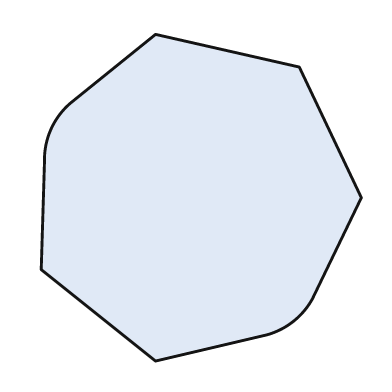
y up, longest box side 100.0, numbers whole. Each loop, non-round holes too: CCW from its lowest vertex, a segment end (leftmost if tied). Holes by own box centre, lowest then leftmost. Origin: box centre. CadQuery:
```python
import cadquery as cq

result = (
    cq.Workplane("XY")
    .moveTo(-14.0, -50.0)
    .lineTo(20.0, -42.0)
    .threePointArc((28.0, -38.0), (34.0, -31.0))
    .lineTo(49.0, 0.0)
    .lineTo(30.0, 40.0)
    .lineTo(-14.0, 50.0)
    .lineTo(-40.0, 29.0)
    .threePointArc((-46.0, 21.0), (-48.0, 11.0))
    .lineTo(-49.0, -22.0)
    .close()
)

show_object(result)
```